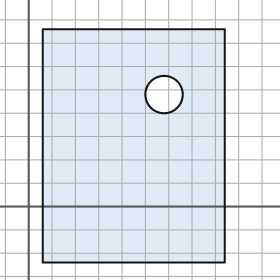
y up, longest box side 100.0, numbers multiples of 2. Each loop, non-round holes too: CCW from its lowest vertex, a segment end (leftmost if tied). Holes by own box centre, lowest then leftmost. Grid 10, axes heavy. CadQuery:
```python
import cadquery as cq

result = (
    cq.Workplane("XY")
    .moveTo(6.0, -24.0)
    .lineTo(84.0, -24.0)
    .lineTo(84.0, 76.0)
    .lineTo(6.0, 76.0)
    .close()
    .moveTo(58.0, 48.0)
    .circle(8.0)
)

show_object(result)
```